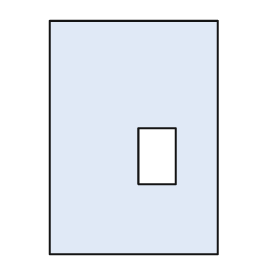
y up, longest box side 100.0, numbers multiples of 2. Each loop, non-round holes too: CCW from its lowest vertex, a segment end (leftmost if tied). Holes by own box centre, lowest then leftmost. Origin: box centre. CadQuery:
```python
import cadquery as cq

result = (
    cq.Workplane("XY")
    .moveTo(-36.0, -50.0)
    .lineTo(36.0, -50.0)
    .lineTo(36.0, 50.0)
    .lineTo(-36.0, 50.0)
    .close()
    .moveTo(2.0, -20.0)
    .lineTo(18.0, -20.0)
    .lineTo(18.0, 4.0)
    .lineTo(2.0, 4.0)
    .close()
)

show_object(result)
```